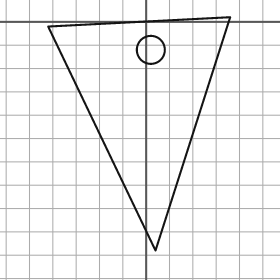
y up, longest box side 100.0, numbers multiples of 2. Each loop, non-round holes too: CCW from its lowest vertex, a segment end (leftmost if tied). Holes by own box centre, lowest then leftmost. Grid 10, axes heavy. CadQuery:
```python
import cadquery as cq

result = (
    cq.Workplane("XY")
    .moveTo(4.0, -98.0)
    .lineTo(36.0, 2.0)
    .lineTo(-42.0, -2.0)
    .close()
    .moveTo(2.0, -12.0)
    .circle(6.0)
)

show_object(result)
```